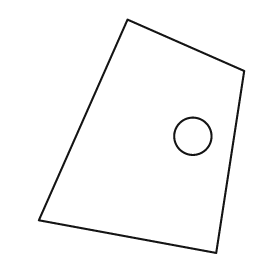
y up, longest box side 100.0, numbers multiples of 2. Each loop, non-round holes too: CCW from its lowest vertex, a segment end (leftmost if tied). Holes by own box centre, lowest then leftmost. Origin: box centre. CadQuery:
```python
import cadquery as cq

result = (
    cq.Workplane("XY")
    .moveTo(32.0, -50.0)
    .lineTo(44.0, 28.0)
    .lineTo(-6.0, 50.0)
    .lineTo(-44.0, -36.0)
    .close()
    .moveTo(22.0, 0.0)
    .circle(8.0)
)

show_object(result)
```